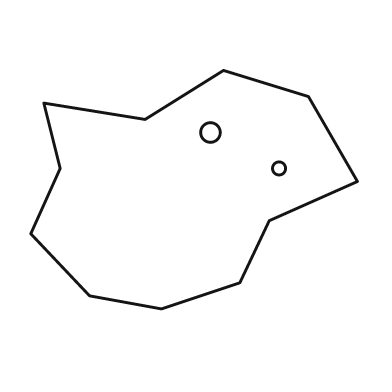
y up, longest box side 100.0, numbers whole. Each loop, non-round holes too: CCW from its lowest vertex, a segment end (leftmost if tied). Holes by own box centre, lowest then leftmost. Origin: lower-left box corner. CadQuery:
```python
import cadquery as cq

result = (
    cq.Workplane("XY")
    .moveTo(40.0, 0.0)
    .lineTo(64.0, 8.0)
    .lineTo(73.0, 27.0)
    .lineTo(100.0, 39.0)
    .lineTo(85.0, 65.0)
    .lineTo(59.0, 73.0)
    .lineTo(35.0, 58.0)
    .lineTo(4.0, 63.0)
    .lineTo(9.0, 43.0)
    .lineTo(0.0, 23.0)
    .lineTo(18.0, 4.0)
    .close()
    .moveTo(76.0, 43.0)
    .circle(2.0)
    .moveTo(55.0, 54.0)
    .circle(3.0)
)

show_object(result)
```